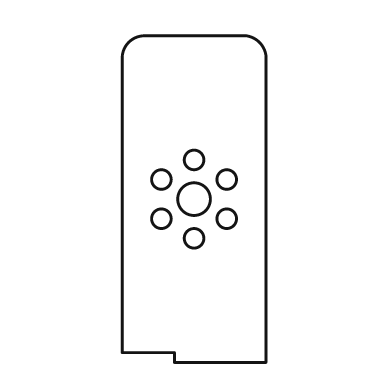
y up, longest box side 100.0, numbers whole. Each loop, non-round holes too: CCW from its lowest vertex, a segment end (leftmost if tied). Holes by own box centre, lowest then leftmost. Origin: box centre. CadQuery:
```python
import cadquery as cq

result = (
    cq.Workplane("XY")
    .moveTo(-6.0, -50.0)
    .lineTo(22.0, -50.0)
    .lineTo(22.0, 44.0)
    .threePointArc((20.0, 48.0), (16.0, 50.0))
    .lineTo(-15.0, 50.0)
    .threePointArc((-20.0, 48.0), (-22.0, 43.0))
    .lineTo(-22.0, -47.0)
    .lineTo(-6.0, -47.0)
    .close()
    .moveTo(0.0, -12.0)
    .circle(3.0)
    .moveTo(-10.0, -6.0)
    .circle(3.0)
    .moveTo(10.0, -6.0)
    .circle(3.0)
    .moveTo(0.0, 0.0)
    .circle(5.0)
    .moveTo(-10.0, 6.0)
    .circle(3.0)
    .moveTo(10.0, 6.0)
    .circle(3.0)
    .moveTo(0.0, 12.0)
    .circle(3.0)
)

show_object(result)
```